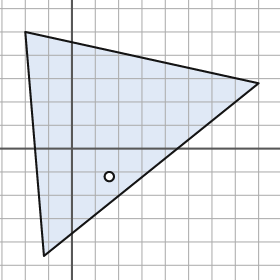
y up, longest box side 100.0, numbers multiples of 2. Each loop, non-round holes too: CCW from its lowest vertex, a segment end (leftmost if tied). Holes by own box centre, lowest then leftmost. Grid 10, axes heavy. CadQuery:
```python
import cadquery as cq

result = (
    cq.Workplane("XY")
    .moveTo(-12.0, -46.0)
    .lineTo(80.0, 28.0)
    .lineTo(-20.0, 50.0)
    .close()
    .moveTo(16.0, -12.0)
    .circle(2.0)
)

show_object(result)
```